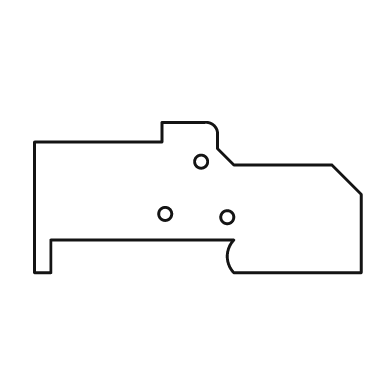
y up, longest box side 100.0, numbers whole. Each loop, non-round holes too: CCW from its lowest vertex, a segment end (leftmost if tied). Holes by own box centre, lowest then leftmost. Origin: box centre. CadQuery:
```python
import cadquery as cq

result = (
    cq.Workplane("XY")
    .moveTo(-50.0, -23.0)
    .lineTo(-45.0, -23.0)
    .lineTo(-45.0, -13.0)
    .lineTo(11.0, -13.0)
    .threePointArc((9.0, -18.0), (11.0, -23.0))
    .lineTo(50.0, -23.0)
    .lineTo(50.0, 1.0)
    .lineTo(41.0, 10.0)
    .lineTo(11.0, 10.0)
    .lineTo(6.0, 15.0)
    .lineTo(6.0, 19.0)
    .threePointArc((5.0, 22.0), (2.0, 23.0))
    .lineTo(-11.0, 23.0)
    .lineTo(-11.0, 17.0)
    .lineTo(-50.0, 17.0)
    .close()
    .moveTo(9.0, -6.0)
    .circle(2.0)
    .moveTo(-10.0, -5.0)
    .circle(2.0)
    .moveTo(1.0, 11.0)
    .circle(2.0)
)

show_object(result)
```